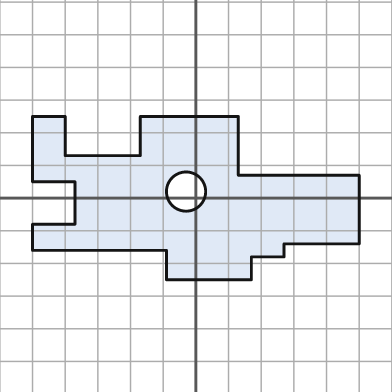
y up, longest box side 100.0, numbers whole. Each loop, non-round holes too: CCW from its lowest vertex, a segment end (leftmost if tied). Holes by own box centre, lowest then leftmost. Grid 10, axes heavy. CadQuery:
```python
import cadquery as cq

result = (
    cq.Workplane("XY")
    .moveTo(-9.0, -25.0)
    .lineTo(17.0, -25.0)
    .lineTo(17.0, -18.0)
    .lineTo(27.0, -18.0)
    .lineTo(27.0, -14.0)
    .lineTo(50.0, -14.0)
    .lineTo(50.0, 7.0)
    .lineTo(13.0, 7.0)
    .lineTo(13.0, 25.0)
    .lineTo(-17.0, 25.0)
    .lineTo(-17.0, 13.0)
    .lineTo(-40.0, 13.0)
    .lineTo(-40.0, 25.0)
    .lineTo(-50.0, 25.0)
    .lineTo(-50.0, 5.0)
    .lineTo(-37.0, 5.0)
    .lineTo(-37.0, -8.0)
    .lineTo(-50.0, -8.0)
    .lineTo(-50.0, -16.0)
    .lineTo(-9.0, -16.0)
    .close()
    .moveTo(-3.0, 2.0)
    .circle(6.0)
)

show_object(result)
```